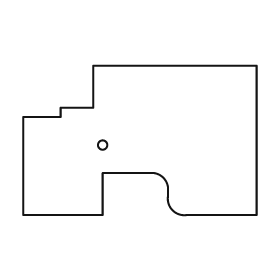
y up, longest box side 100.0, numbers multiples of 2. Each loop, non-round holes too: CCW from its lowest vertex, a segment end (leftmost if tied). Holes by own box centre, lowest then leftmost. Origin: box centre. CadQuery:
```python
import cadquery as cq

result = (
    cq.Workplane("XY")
    .moveTo(-50.0, -32.0)
    .lineTo(-16.0, -32.0)
    .lineTo(-16.0, -14.0)
    .lineTo(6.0, -14.0)
    .threePointArc((10.0, -16.0), (12.0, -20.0))
    .lineTo(12.0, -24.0)
    .threePointArc((14.0, -30.0), (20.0, -32.0))
    .lineTo(50.0, -32.0)
    .lineTo(50.0, 32.0)
    .lineTo(-20.0, 32.0)
    .lineTo(-20.0, 14.0)
    .lineTo(-34.0, 14.0)
    .lineTo(-34.0, 10.0)
    .lineTo(-50.0, 10.0)
    .close()
    .moveTo(-16.0, -2.0)
    .circle(2.0)
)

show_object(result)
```